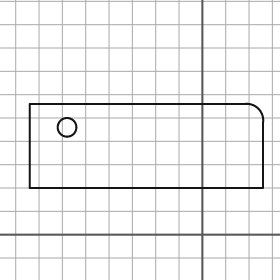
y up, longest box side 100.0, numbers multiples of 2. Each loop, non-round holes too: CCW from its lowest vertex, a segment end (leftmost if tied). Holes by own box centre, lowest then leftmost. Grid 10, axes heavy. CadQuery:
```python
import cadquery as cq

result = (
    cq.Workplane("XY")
    .moveTo(-74.0, 20.0)
    .lineTo(26.0, 20.0)
    .lineTo(26.0, 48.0)
    .threePointArc((24.0, 54.0), (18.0, 56.0))
    .lineTo(-74.0, 56.0)
    .close()
    .moveTo(-58.0, 46.0)
    .circle(4.0)
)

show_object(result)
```